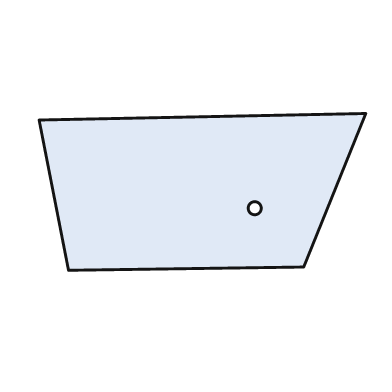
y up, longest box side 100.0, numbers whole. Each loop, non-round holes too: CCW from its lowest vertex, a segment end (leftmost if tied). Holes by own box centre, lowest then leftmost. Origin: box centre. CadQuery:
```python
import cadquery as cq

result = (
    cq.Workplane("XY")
    .moveTo(-41.0, -24.0)
    .lineTo(31.0, -23.0)
    .lineTo(50.0, 24.0)
    .lineTo(-50.0, 22.0)
    .close()
    .moveTo(16.0, -5.0)
    .circle(2.0)
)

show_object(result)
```